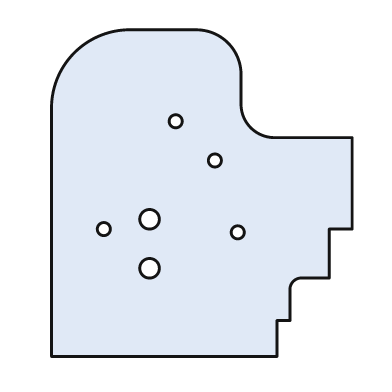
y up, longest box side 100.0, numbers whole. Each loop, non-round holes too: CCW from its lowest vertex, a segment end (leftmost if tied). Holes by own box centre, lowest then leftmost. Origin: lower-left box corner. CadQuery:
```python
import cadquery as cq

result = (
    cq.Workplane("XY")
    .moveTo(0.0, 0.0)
    .lineTo(69.0, 0.0)
    .lineTo(69.0, 11.0)
    .lineTo(73.0, 11.0)
    .lineTo(73.0, 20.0)
    .threePointArc((74.0, 23.0), (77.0, 24.0))
    .lineTo(85.0, 24.0)
    .lineTo(85.0, 39.0)
    .lineTo(92.0, 39.0)
    .lineTo(92.0, 67.0)
    .lineTo(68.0, 67.0)
    .threePointArc((61.0, 70.0), (58.0, 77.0))
    .lineTo(58.0, 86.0)
    .threePointArc((54.0, 96.0), (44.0, 100.0))
    .lineTo(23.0, 100.0)
    .threePointArc((7.0, 93.0), (0.0, 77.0))
    .close()
    .moveTo(30.0, 27.0)
    .circle(3.0)
    .moveTo(57.0, 38.0)
    .circle(2.0)
    .moveTo(16.0, 39.0)
    .circle(2.0)
    .moveTo(30.0, 42.0)
    .circle(3.0)
    .moveTo(50.0, 60.0)
    .circle(2.0)
    .moveTo(38.0, 72.0)
    .circle(2.0)
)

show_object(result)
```